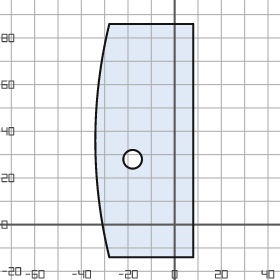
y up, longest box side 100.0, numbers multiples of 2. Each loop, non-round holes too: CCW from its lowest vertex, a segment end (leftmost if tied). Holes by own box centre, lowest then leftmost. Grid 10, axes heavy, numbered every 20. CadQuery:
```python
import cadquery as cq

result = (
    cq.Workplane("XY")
    .moveTo(-28.0, -14.0)
    .lineTo(8.0, -14.0)
    .lineTo(8.0, 86.0)
    .lineTo(-28.0, 86.0)
    .threePointArc((-34.0, 36.0), (-28.0, -14.0))
    .close()
    .moveTo(-18.0, 28.0)
    .circle(4.0)
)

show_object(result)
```